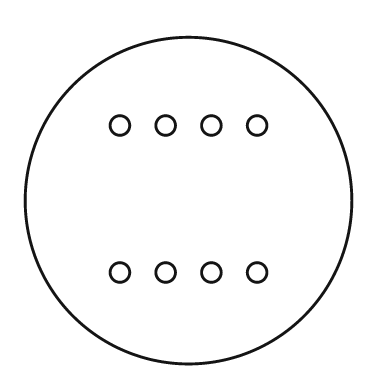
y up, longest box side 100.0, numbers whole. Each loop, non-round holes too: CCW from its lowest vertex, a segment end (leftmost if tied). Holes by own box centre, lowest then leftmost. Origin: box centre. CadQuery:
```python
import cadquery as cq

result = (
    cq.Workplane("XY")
    .moveTo(0.0, 0.0)
    .circle(50.0)
    .moveTo(-21.0, -22.0)
    .circle(3.0)
    .moveTo(-7.0, -22.0)
    .circle(3.0)
    .moveTo(7.0, -22.0)
    .circle(3.0)
    .moveTo(21.0, -22.0)
    .circle(3.0)
    .moveTo(-21.0, 23.0)
    .circle(3.0)
    .moveTo(-7.0, 23.0)
    .circle(3.0)
    .moveTo(7.0, 23.0)
    .circle(3.0)
    .moveTo(21.0, 23.0)
    .circle(3.0)
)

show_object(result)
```